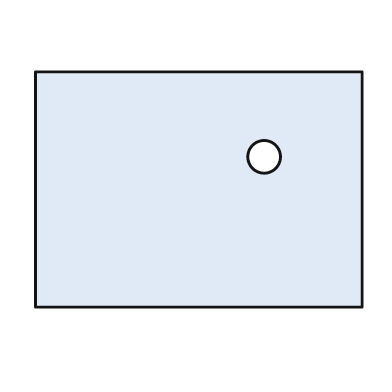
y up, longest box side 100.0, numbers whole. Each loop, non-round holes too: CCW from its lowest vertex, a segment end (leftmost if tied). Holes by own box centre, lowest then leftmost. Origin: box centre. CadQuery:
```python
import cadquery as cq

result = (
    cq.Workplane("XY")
    .moveTo(-50.0, -36.0)
    .lineTo(50.0, -36.0)
    .lineTo(50.0, 36.0)
    .lineTo(-50.0, 36.0)
    .close()
    .moveTo(20.0, 10.0)
    .circle(5.0)
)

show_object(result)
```